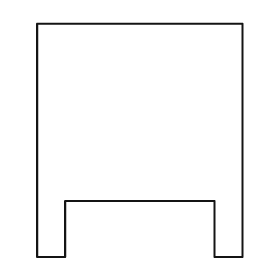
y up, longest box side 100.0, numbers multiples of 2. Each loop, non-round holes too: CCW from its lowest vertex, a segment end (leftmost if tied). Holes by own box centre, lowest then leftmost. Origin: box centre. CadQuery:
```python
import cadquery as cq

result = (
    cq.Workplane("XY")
    .moveTo(-44.0, -50.0)
    .lineTo(-32.0, -50.0)
    .lineTo(-32.0, -26.0)
    .lineTo(32.0, -26.0)
    .lineTo(32.0, -50.0)
    .lineTo(44.0, -50.0)
    .lineTo(44.0, 50.0)
    .lineTo(-44.0, 50.0)
    .close()
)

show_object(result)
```